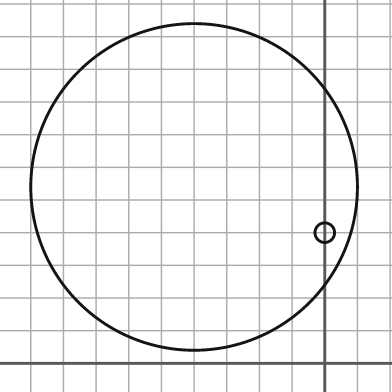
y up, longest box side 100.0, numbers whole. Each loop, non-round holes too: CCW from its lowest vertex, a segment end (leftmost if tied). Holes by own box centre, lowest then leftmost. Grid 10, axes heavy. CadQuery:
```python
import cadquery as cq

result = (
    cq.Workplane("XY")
    .moveTo(-40.0, 54.0)
    .circle(50.0)
    .moveTo(0.0, 40.0)
    .circle(3.0)
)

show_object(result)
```